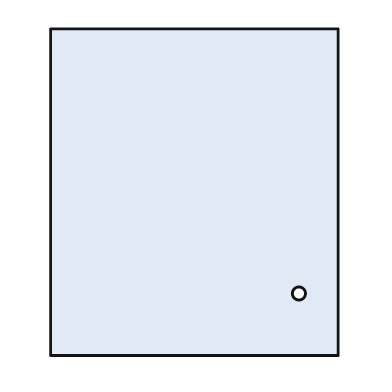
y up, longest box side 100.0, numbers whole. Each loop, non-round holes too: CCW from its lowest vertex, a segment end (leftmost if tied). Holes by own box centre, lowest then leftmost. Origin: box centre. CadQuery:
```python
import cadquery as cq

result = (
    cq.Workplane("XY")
    .moveTo(-44.0, -50.0)
    .lineTo(44.0, -50.0)
    .lineTo(44.0, 50.0)
    .lineTo(-44.0, 50.0)
    .close()
    .moveTo(32.0, -31.0)
    .circle(2.0)
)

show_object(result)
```